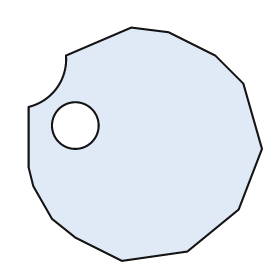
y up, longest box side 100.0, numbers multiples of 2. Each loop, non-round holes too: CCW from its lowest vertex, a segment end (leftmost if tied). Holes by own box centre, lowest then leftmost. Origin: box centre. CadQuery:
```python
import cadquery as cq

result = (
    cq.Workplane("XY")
    .moveTo(-10.0, -50.0)
    .lineTo(18.0, -46.0)
    .lineTo(40.0, -28.0)
    .lineTo(50.0, -2.0)
    .lineTo(42.0, 26.0)
    .lineTo(30.0, 38.0)
    .lineTo(10.0, 48.0)
    .lineTo(-6.0, 50.0)
    .lineTo(-34.0, 38.0)
    .threePointArc((-38.0, 24.0), (-50.0, 16.0))
    .lineTo(-50.0, -10.0)
    .lineTo(-48.0, -18.0)
    .lineTo(-40.0, -32.0)
    .lineTo(-30.0, -40.0)
    .close()
    .moveTo(-30.0, 8.0)
    .circle(10.0)
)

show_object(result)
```